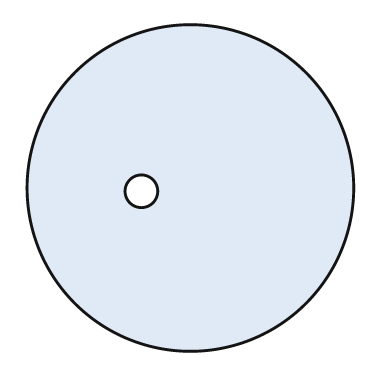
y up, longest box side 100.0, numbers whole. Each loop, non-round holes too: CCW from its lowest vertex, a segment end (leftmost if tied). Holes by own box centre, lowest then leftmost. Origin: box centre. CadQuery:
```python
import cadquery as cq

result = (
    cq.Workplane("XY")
    .moveTo(0.0, 0.0)
    .circle(50.0)
    .moveTo(-15.0, -1.0)
    .circle(5.0)
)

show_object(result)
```